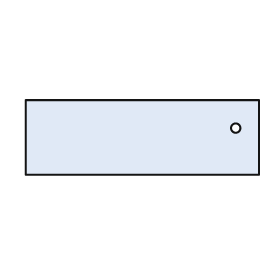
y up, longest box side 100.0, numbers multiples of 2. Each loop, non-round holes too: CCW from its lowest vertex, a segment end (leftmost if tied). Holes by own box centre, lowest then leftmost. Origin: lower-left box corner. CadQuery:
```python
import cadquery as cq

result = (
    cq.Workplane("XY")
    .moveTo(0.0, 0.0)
    .lineTo(100.0, 0.0)
    .lineTo(100.0, 32.0)
    .lineTo(0.0, 32.0)
    .close()
    .moveTo(90.0, 20.0)
    .circle(2.0)
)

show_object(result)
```